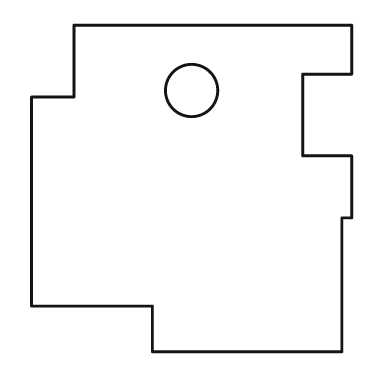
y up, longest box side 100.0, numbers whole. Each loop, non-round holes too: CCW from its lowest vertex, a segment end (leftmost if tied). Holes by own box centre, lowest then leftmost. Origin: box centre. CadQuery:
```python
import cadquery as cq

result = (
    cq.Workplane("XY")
    .moveTo(-12.0, -50.0)
    .lineTo(46.0, -50.0)
    .lineTo(46.0, -9.0)
    .lineTo(49.0, -9.0)
    .lineTo(49.0, 10.0)
    .lineTo(34.0, 10.0)
    .lineTo(34.0, 35.0)
    .lineTo(49.0, 35.0)
    .lineTo(49.0, 50.0)
    .lineTo(-36.0, 50.0)
    .lineTo(-36.0, 28.0)
    .lineTo(-49.0, 28.0)
    .lineTo(-49.0, -36.0)
    .lineTo(-12.0, -36.0)
    .close()
    .moveTo(0.0, 30.0)
    .circle(8.0)
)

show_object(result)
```